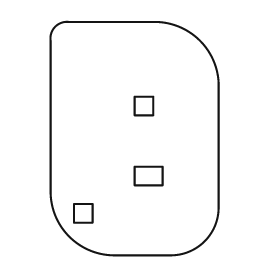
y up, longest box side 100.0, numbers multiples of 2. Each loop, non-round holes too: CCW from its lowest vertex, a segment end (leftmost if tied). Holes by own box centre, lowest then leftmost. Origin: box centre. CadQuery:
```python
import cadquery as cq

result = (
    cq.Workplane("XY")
    .moveTo(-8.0, -50.0)
    .lineTo(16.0, -50.0)
    .threePointArc((30.0, -44.0), (36.0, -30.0))
    .lineTo(36.0, 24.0)
    .threePointArc((28.0, 42.0), (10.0, 50.0))
    .lineTo(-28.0, 50.0)
    .threePointArc((-34.0, 48.0), (-36.0, 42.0))
    .lineTo(-36.0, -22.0)
    .threePointArc((-28.0, -42.0), (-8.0, -50.0))
    .close()
    .moveTo(-26.0, -36.0)
    .lineTo(-18.0, -36.0)
    .lineTo(-18.0, -28.0)
    .lineTo(-26.0, -28.0)
    .close()
    .moveTo(0.0, -20.0)
    .lineTo(12.0, -20.0)
    .lineTo(12.0, -12.0)
    .lineTo(0.0, -12.0)
    .close()
    .moveTo(0.0, 10.0)
    .lineTo(8.0, 10.0)
    .lineTo(8.0, 18.0)
    .lineTo(0.0, 18.0)
    .close()
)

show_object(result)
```